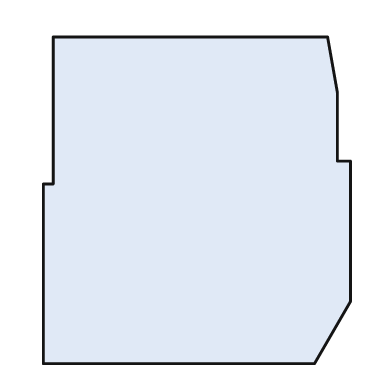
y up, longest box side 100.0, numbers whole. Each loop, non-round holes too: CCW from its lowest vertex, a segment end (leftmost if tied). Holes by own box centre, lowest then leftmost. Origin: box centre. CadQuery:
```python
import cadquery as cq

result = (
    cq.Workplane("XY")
    .moveTo(-47.0, -50.0)
    .lineTo(36.0, -50.0)
    .lineTo(47.0, -31.0)
    .lineTo(47.0, 12.0)
    .lineTo(43.0, 12.0)
    .lineTo(43.0, 33.0)
    .lineTo(40.0, 50.0)
    .lineTo(-44.0, 50.0)
    .lineTo(-44.0, 5.0)
    .lineTo(-47.0, 5.0)
    .close()
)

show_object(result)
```